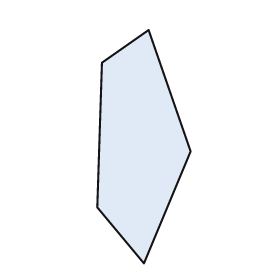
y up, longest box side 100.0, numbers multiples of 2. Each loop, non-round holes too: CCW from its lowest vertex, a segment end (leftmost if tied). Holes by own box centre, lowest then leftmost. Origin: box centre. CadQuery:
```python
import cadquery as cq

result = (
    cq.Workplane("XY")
    .moveTo(0.0, -50.0)
    .lineTo(20.0, -2.0)
    .lineTo(2.0, 50.0)
    .lineTo(-18.0, 36.0)
    .lineTo(-20.0, -26.0)
    .close()
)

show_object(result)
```